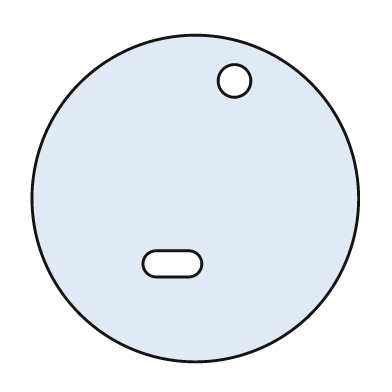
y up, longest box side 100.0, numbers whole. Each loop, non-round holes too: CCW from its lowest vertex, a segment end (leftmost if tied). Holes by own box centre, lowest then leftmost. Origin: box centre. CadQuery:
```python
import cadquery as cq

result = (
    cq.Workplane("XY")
    .moveTo(0.0, 0.0)
    .circle(50.0)
    .moveTo(-12.0, -24.0)
    .lineTo(-2.0, -24.0)
    .threePointArc((2.0, -20.0), (-2.0, -16.0))
    .lineTo(-12.0, -16.0)
    .threePointArc((-16.0, -20.0), (-12.0, -24.0))
    .close()
    .moveTo(12.0, 36.0)
    .circle(5.0)
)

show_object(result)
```